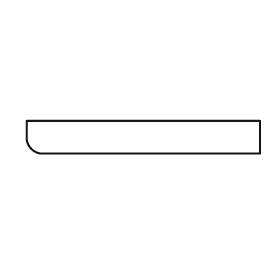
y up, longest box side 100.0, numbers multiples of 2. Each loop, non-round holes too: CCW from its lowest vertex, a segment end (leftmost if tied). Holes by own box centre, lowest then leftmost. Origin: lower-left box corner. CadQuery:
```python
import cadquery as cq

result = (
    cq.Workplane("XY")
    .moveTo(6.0, 0.0)
    .lineTo(100.0, 0.0)
    .lineTo(100.0, 14.0)
    .lineTo(0.0, 14.0)
    .lineTo(0.0, 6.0)
    .threePointArc((2.0, 2.0), (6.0, 0.0))
    .close()
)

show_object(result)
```